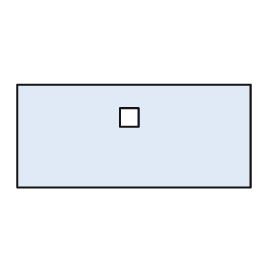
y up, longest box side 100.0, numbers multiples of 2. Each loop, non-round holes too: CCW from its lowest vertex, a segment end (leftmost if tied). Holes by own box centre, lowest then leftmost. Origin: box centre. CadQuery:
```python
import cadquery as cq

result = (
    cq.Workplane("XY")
    .moveTo(-50.0, -22.0)
    .lineTo(50.0, -22.0)
    .lineTo(50.0, 22.0)
    .lineTo(-50.0, 22.0)
    .close()
    .moveTo(-6.0, 4.0)
    .lineTo(2.0, 4.0)
    .lineTo(2.0, 12.0)
    .lineTo(-6.0, 12.0)
    .close()
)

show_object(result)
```